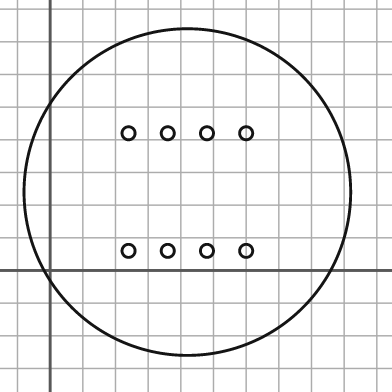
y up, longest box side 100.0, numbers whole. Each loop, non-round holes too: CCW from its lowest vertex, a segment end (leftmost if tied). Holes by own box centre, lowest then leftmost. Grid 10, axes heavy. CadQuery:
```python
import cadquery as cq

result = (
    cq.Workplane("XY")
    .moveTo(42.0, 24.0)
    .circle(50.0)
    .moveTo(24.0, 6.0)
    .circle(2.0)
    .moveTo(36.0, 6.0)
    .circle(2.0)
    .moveTo(48.0, 6.0)
    .circle(2.0)
    .moveTo(60.0, 6.0)
    .circle(2.0)
    .moveTo(24.0, 42.0)
    .circle(2.0)
    .moveTo(36.0, 42.0)
    .circle(2.0)
    .moveTo(48.0, 42.0)
    .circle(2.0)
    .moveTo(60.0, 42.0)
    .circle(2.0)
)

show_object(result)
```